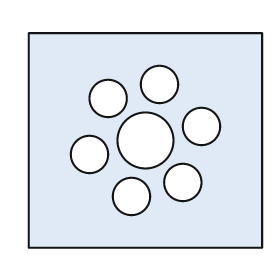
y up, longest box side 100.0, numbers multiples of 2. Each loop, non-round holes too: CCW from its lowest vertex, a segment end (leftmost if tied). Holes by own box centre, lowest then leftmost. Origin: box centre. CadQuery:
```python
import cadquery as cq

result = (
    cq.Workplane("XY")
    .moveTo(-50.0, -46.0)
    .lineTo(50.0, -46.0)
    .lineTo(50.0, 46.0)
    .lineTo(-50.0, 46.0)
    .close()
    .moveTo(-6.0, -24.0)
    .circle(8.0)
    .moveTo(16.0, -18.0)
    .circle(8.0)
    .moveTo(-24.0, -6.0)
    .circle(8.0)
    .moveTo(0.0, 0.0)
    .circle(12.0)
    .moveTo(24.0, 6.0)
    .circle(8.0)
    .moveTo(-16.0, 18.0)
    .circle(8.0)
    .moveTo(6.0, 24.0)
    .circle(8.0)
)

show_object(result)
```